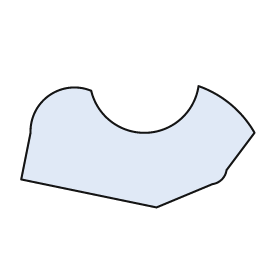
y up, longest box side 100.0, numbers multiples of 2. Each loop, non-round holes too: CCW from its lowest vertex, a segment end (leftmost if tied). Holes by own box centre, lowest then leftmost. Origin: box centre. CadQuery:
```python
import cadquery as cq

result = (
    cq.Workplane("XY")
    .moveTo(8.0, -26.0)
    .lineTo(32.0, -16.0)
    .threePointArc((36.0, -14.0), (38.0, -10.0))
    .lineTo(50.0, 6.0)
    .threePointArc((40.0, 18.0), (26.0, 26.0))
    .threePointArc((4.0, 6.0), (-20.0, 24.0))
    .threePointArc((-38.0, 22.0), (-46.0, 6.0))
    .lineTo(-50.0, -14.0)
    .close()
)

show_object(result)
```